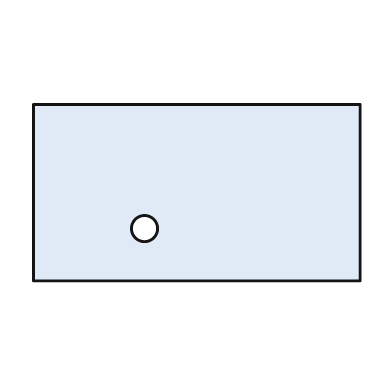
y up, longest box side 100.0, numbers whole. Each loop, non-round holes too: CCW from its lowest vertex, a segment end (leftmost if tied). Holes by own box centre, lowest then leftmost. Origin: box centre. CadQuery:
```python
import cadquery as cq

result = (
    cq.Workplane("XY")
    .moveTo(-50.0, -27.0)
    .lineTo(50.0, -27.0)
    .lineTo(50.0, 27.0)
    .lineTo(-50.0, 27.0)
    .close()
    .moveTo(-16.0, -11.0)
    .circle(4.0)
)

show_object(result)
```